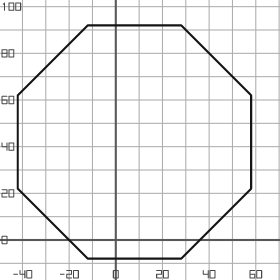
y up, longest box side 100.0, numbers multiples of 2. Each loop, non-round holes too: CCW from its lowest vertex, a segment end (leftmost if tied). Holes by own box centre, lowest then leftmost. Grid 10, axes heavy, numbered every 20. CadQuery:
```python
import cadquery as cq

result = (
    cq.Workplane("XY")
    .moveTo(-12.0, -8.0)
    .lineTo(28.0, -8.0)
    .lineTo(58.0, 22.0)
    .lineTo(58.0, 62.0)
    .lineTo(28.0, 92.0)
    .lineTo(-12.0, 92.0)
    .lineTo(-42.0, 62.0)
    .lineTo(-42.0, 22.0)
    .close()
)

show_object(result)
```